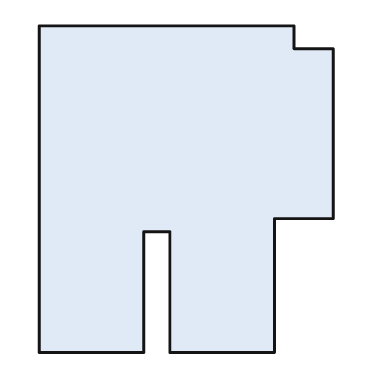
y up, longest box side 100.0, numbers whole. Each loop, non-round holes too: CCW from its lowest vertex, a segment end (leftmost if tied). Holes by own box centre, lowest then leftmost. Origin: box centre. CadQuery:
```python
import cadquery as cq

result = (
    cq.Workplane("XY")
    .moveTo(-45.0, -50.0)
    .lineTo(-13.0, -50.0)
    .lineTo(-13.0, -13.0)
    .lineTo(-5.0, -13.0)
    .lineTo(-5.0, -50.0)
    .lineTo(27.0, -50.0)
    .lineTo(27.0, -9.0)
    .lineTo(45.0, -9.0)
    .lineTo(45.0, 43.0)
    .lineTo(33.0, 43.0)
    .lineTo(33.0, 50.0)
    .lineTo(-45.0, 50.0)
    .close()
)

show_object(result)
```